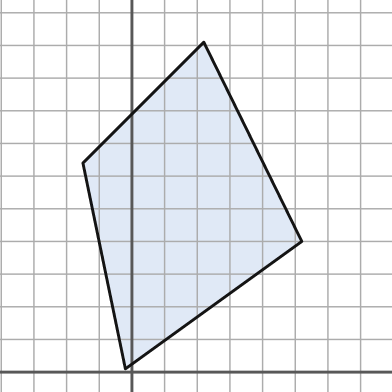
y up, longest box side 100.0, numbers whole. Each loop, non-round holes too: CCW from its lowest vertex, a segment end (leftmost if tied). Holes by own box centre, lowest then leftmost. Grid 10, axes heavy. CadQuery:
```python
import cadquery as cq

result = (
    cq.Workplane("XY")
    .moveTo(-2.0, 1.0)
    .lineTo(52.0, 40.0)
    .lineTo(22.0, 101.0)
    .lineTo(-15.0, 64.0)
    .close()
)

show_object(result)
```